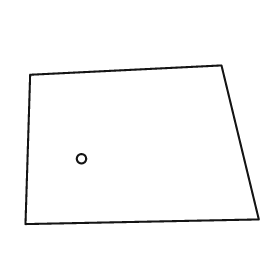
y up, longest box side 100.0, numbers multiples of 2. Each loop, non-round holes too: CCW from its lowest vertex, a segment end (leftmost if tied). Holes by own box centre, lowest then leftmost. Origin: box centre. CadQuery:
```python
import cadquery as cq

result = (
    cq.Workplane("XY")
    .moveTo(-50.0, -34.0)
    .lineTo(50.0, -32.0)
    .lineTo(34.0, 34.0)
    .lineTo(-48.0, 30.0)
    .close()
    .moveTo(-26.0, -6.0)
    .circle(2.0)
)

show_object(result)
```